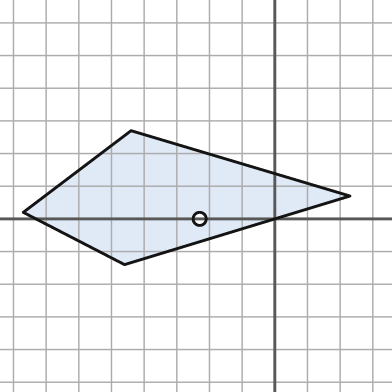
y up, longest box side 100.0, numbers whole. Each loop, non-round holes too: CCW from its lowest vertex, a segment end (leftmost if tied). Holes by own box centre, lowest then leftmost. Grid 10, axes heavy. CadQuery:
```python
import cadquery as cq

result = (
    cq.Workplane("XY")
    .moveTo(-46.0, -14.0)
    .lineTo(23.0, 7.0)
    .lineTo(-44.0, 27.0)
    .lineTo(-77.0, 2.0)
    .close()
    .moveTo(-23.0, 0.0)
    .circle(2.0)
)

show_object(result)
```